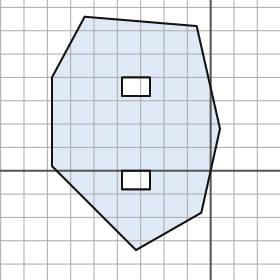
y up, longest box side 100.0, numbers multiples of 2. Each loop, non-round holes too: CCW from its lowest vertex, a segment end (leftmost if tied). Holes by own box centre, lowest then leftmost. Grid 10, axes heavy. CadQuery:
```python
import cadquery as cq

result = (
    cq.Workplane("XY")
    .moveTo(-32.0, -34.0)
    .lineTo(-4.0, -18.0)
    .lineTo(4.0, 18.0)
    .lineTo(-6.0, 62.0)
    .lineTo(-54.0, 66.0)
    .lineTo(-68.0, 40.0)
    .lineTo(-68.0, 2.0)
    .close()
    .moveTo(-38.0, -8.0)
    .lineTo(-26.0, -8.0)
    .lineTo(-26.0, 0.0)
    .lineTo(-38.0, 0.0)
    .close()
    .moveTo(-38.0, 32.0)
    .lineTo(-26.0, 32.0)
    .lineTo(-26.0, 40.0)
    .lineTo(-38.0, 40.0)
    .close()
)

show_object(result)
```